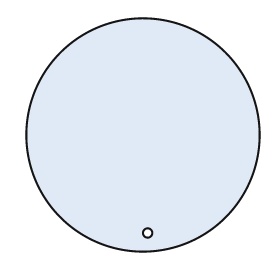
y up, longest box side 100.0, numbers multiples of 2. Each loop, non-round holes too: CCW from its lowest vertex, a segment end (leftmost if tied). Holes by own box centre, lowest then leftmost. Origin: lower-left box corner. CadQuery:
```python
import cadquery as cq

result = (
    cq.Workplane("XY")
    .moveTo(50.0, 50.0)
    .circle(50.0)
    .moveTo(52.0, 8.0)
    .circle(2.0)
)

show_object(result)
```